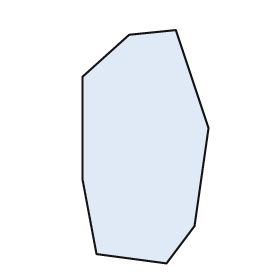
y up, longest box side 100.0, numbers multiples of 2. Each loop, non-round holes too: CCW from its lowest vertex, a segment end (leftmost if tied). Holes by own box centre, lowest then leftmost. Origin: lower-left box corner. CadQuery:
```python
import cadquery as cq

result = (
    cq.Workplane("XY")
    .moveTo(36.0, 0.0)
    .lineTo(48.0, 16.0)
    .lineTo(54.0, 58.0)
    .lineTo(40.0, 100.0)
    .lineTo(20.0, 98.0)
    .lineTo(0.0, 80.0)
    .lineTo(0.0, 36.0)
    .lineTo(6.0, 4.0)
    .close()
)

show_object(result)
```